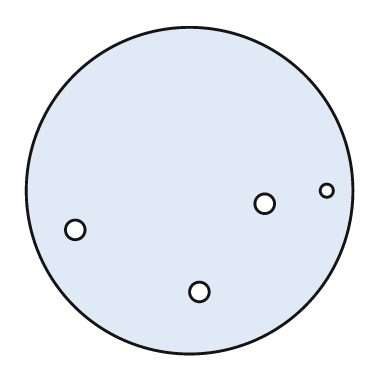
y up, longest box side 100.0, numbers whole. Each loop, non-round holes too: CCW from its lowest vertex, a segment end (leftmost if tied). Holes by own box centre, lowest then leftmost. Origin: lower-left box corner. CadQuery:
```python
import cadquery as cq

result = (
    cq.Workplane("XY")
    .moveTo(50.0, 50.0)
    .circle(50.0)
    .moveTo(53.0, 19.0)
    .circle(3.0)
    .moveTo(15.0, 38.0)
    .circle(3.0)
    .moveTo(73.0, 46.0)
    .circle(3.0)
    .moveTo(92.0, 50.0)
    .circle(2.0)
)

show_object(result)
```